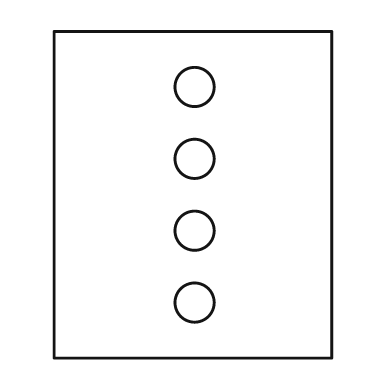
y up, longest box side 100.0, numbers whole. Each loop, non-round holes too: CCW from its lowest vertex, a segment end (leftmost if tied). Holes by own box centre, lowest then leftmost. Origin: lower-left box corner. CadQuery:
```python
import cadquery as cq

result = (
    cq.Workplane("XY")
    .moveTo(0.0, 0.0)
    .lineTo(85.0, 0.0)
    .lineTo(85.0, 100.0)
    .lineTo(0.0, 100.0)
    .close()
    .moveTo(43.0, 17.0)
    .circle(6.0)
    .moveTo(43.0, 39.0)
    .circle(6.0)
    .moveTo(43.0, 61.0)
    .circle(6.0)
    .moveTo(43.0, 83.0)
    .circle(6.0)
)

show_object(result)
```